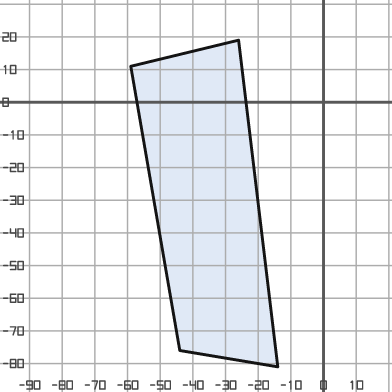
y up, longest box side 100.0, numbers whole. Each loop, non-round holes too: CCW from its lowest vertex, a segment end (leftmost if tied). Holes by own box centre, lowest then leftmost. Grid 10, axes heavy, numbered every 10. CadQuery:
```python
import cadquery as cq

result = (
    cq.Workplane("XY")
    .moveTo(-14.0, -81.0)
    .lineTo(-26.0, 19.0)
    .lineTo(-59.0, 11.0)
    .lineTo(-44.0, -76.0)
    .close()
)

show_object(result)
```